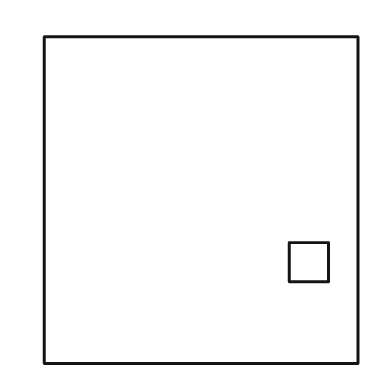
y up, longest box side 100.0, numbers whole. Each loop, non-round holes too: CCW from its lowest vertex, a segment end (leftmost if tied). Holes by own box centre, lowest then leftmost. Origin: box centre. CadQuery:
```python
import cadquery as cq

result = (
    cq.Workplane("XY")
    .moveTo(-48.0, -50.0)
    .lineTo(48.0, -50.0)
    .lineTo(48.0, 50.0)
    .lineTo(-48.0, 50.0)
    .close()
    .moveTo(27.0, -25.0)
    .lineTo(39.0, -25.0)
    .lineTo(39.0, -13.0)
    .lineTo(27.0, -13.0)
    .close()
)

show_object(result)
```